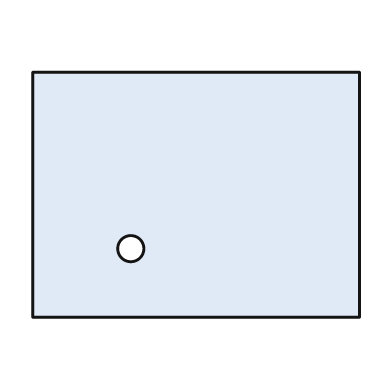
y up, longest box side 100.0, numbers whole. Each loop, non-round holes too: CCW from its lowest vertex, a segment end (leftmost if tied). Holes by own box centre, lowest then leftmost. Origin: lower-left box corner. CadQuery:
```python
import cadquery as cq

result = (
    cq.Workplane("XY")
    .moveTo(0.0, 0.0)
    .lineTo(100.0, 0.0)
    .lineTo(100.0, 75.0)
    .lineTo(0.0, 75.0)
    .close()
    .moveTo(30.0, 21.0)
    .circle(4.0)
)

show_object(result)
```